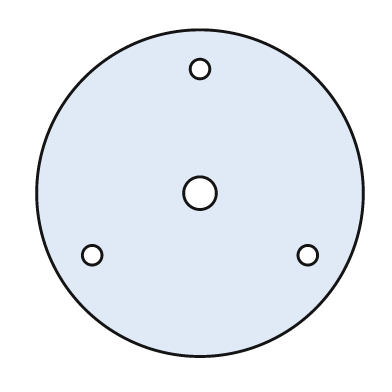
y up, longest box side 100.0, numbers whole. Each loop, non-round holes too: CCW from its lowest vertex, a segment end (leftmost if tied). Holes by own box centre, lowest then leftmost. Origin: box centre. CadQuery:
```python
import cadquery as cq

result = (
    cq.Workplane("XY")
    .moveTo(0.0, 0.0)
    .circle(50.0)
    .moveTo(-33.0, -19.0)
    .circle(3.0)
    .moveTo(33.0, -19.0)
    .circle(3.0)
    .moveTo(0.0, 0.0)
    .circle(5.0)
    .moveTo(0.0, 38.0)
    .circle(3.0)
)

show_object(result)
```